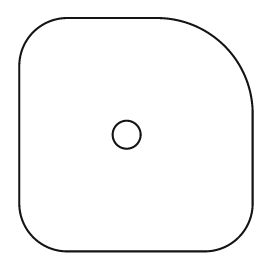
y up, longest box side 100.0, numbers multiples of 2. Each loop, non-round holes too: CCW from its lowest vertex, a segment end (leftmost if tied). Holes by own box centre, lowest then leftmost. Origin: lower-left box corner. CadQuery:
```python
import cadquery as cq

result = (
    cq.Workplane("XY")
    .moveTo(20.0, 0.0)
    .lineTo(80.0, 0.0)
    .threePointArc((94.0, 6.0), (100.0, 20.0))
    .lineTo(100.0, 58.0)
    .threePointArc((88.0, 88.0), (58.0, 100.0))
    .lineTo(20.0, 100.0)
    .threePointArc((6.0, 94.0), (0.0, 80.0))
    .lineTo(0.0, 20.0)
    .threePointArc((6.0, 6.0), (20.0, 0.0))
    .close()
    .moveTo(46.0, 50.0)
    .circle(6.0)
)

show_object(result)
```